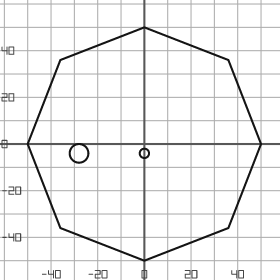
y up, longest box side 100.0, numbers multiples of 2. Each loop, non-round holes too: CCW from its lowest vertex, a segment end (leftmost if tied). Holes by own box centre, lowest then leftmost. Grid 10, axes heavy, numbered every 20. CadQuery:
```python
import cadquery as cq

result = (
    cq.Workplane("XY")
    .moveTo(0.0, -50.0)
    .lineTo(36.0, -36.0)
    .lineTo(50.0, 0.0)
    .lineTo(36.0, 36.0)
    .lineTo(0.0, 50.0)
    .lineTo(-36.0, 36.0)
    .lineTo(-50.0, 0.0)
    .lineTo(-36.0, -36.0)
    .close()
    .moveTo(-28.0, -4.0)
    .circle(4.0)
    .moveTo(0.0, -4.0)
    .circle(2.0)
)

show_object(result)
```